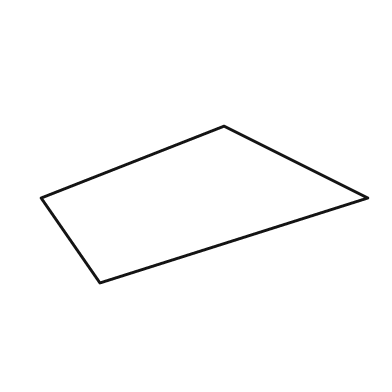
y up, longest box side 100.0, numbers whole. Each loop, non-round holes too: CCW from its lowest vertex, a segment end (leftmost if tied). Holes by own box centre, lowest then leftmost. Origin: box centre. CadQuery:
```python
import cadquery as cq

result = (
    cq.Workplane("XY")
    .moveTo(-32.0, -24.0)
    .lineTo(50.0, 2.0)
    .lineTo(6.0, 24.0)
    .lineTo(-50.0, 2.0)
    .close()
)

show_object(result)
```